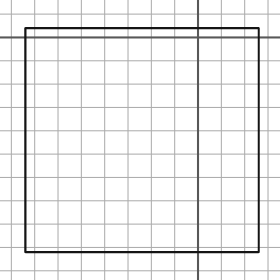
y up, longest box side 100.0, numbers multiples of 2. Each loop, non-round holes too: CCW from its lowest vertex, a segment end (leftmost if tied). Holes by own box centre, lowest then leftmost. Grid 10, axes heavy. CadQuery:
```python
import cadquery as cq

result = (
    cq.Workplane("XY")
    .moveTo(-74.0, -92.0)
    .lineTo(26.0, -92.0)
    .lineTo(26.0, 4.0)
    .lineTo(-74.0, 4.0)
    .close()
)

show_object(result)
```